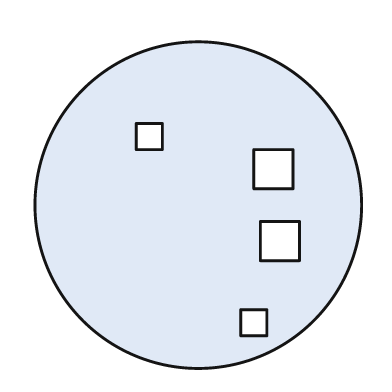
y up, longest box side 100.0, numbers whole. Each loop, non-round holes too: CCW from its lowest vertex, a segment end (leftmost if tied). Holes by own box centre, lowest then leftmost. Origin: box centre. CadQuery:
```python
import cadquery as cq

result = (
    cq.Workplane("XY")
    .moveTo(0.0, 0.0)
    .circle(50.0)
    .moveTo(13.0, -40.0)
    .lineTo(21.0, -40.0)
    .lineTo(21.0, -32.0)
    .lineTo(13.0, -32.0)
    .close()
    .moveTo(19.0, -17.0)
    .lineTo(31.0, -17.0)
    .lineTo(31.0, -5.0)
    .lineTo(19.0, -5.0)
    .close()
    .moveTo(17.0, 5.0)
    .lineTo(29.0, 5.0)
    .lineTo(29.0, 17.0)
    .lineTo(17.0, 17.0)
    .close()
    .moveTo(-19.0, 17.0)
    .lineTo(-11.0, 17.0)
    .lineTo(-11.0, 25.0)
    .lineTo(-19.0, 25.0)
    .close()
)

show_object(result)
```